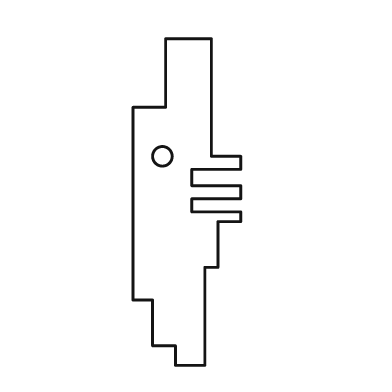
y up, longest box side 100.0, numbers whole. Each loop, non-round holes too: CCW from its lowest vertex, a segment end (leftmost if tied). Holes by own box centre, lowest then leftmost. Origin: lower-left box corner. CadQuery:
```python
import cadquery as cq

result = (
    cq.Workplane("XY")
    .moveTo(13.0, 0.0)
    .lineTo(22.0, 0.0)
    .lineTo(22.0, 30.0)
    .lineTo(26.0, 30.0)
    .lineTo(26.0, 44.0)
    .lineTo(33.0, 44.0)
    .lineTo(33.0, 47.0)
    .lineTo(18.0, 47.0)
    .lineTo(18.0, 51.0)
    .lineTo(33.0, 51.0)
    .lineTo(33.0, 55.0)
    .lineTo(18.0, 55.0)
    .lineTo(18.0, 60.0)
    .lineTo(33.0, 60.0)
    .lineTo(33.0, 64.0)
    .lineTo(24.0, 64.0)
    .lineTo(24.0, 100.0)
    .lineTo(10.0, 100.0)
    .lineTo(10.0, 79.0)
    .lineTo(0.0, 79.0)
    .lineTo(0.0, 20.0)
    .lineTo(6.0, 20.0)
    .lineTo(6.0, 6.0)
    .lineTo(13.0, 6.0)
    .close()
    .moveTo(9.0, 64.0)
    .circle(3.0)
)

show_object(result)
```